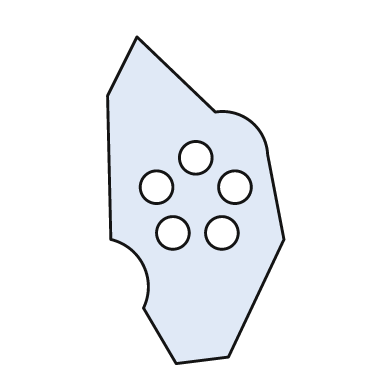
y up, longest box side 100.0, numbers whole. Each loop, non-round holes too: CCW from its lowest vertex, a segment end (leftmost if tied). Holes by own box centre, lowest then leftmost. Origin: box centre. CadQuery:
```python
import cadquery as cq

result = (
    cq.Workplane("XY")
    .moveTo(-6.0, -50.0)
    .lineTo(10.0, -48.0)
    .lineTo(27.0, -12.0)
    .lineTo(22.0, 14.0)
    .threePointArc((17.0, 24.0), (6.0, 27.0))
    .lineTo(-18.0, 50.0)
    .lineTo(-27.0, 32.0)
    .lineTo(-26.0, -12.0)
    .threePointArc((-16.0, -20.0), (-16.0, -33.0))
    .close()
    .moveTo(-7.0, -10.0)
    .circle(5.0)
    .moveTo(8.0, -10.0)
    .circle(5.0)
    .moveTo(-12.0, 4.0)
    .circle(5.0)
    .moveTo(12.0, 4.0)
    .circle(5.0)
    .moveTo(0.0, 13.0)
    .circle(5.0)
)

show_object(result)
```